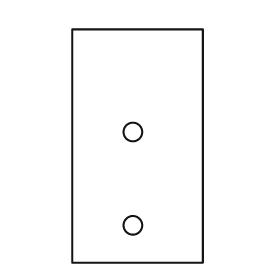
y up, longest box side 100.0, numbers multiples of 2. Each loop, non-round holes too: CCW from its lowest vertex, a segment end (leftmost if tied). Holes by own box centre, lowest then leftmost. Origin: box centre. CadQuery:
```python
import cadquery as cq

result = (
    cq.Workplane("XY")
    .moveTo(-28.0, -50.0)
    .lineTo(28.0, -50.0)
    .lineTo(28.0, 50.0)
    .lineTo(-28.0, 50.0)
    .close()
    .moveTo(-2.0, -34.0)
    .circle(4.0)
    .moveTo(-2.0, 6.0)
    .circle(4.0)
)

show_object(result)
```